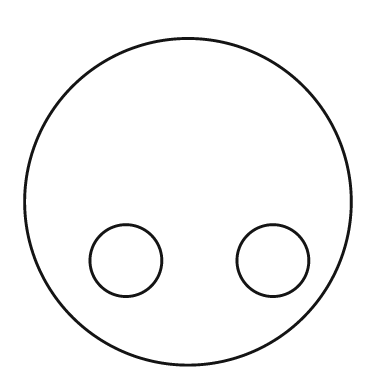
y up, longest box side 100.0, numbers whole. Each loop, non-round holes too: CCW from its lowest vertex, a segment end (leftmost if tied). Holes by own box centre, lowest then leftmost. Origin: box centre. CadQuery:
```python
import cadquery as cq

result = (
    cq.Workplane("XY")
    .moveTo(0.0, 0.0)
    .circle(50.0)
    .moveTo(-19.0, -18.0)
    .circle(11.0)
    .moveTo(26.0, -18.0)
    .circle(11.0)
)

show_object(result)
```